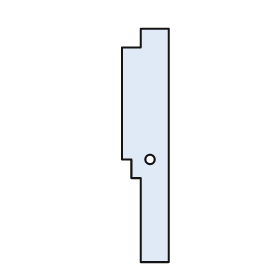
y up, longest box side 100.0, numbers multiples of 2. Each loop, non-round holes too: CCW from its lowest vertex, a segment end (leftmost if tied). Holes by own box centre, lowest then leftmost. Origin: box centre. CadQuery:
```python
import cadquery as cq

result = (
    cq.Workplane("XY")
    .moveTo(-2.0, -50.0)
    .lineTo(10.0, -50.0)
    .lineTo(10.0, 50.0)
    .lineTo(-2.0, 50.0)
    .lineTo(-2.0, 42.0)
    .lineTo(-10.0, 42.0)
    .lineTo(-10.0, -6.0)
    .lineTo(-6.0, -6.0)
    .lineTo(-6.0, -14.0)
    .lineTo(-2.0, -14.0)
    .close()
    .moveTo(2.0, -6.0)
    .circle(2.0)
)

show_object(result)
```